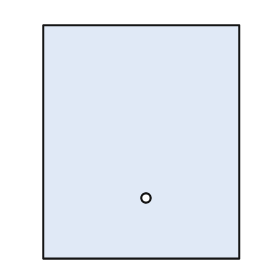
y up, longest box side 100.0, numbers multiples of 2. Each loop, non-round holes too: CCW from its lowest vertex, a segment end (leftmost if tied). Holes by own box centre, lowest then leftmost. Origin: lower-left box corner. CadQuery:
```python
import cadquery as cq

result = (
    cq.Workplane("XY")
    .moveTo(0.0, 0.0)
    .lineTo(84.0, 0.0)
    .lineTo(84.0, 100.0)
    .lineTo(0.0, 100.0)
    .close()
    .moveTo(44.0, 26.0)
    .circle(2.0)
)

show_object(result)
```